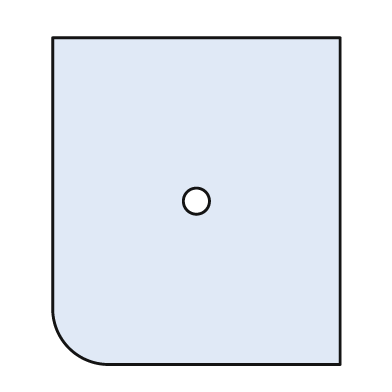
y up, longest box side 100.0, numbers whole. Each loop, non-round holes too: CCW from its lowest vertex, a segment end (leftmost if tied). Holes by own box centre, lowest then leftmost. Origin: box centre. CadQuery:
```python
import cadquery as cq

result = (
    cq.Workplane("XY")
    .moveTo(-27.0, -50.0)
    .lineTo(44.0, -50.0)
    .lineTo(44.0, 50.0)
    .lineTo(-44.0, 50.0)
    .lineTo(-44.0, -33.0)
    .threePointArc((-39.0, -45.0), (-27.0, -50.0))
    .close()
    .moveTo(0.0, 0.0)
    .circle(4.0)
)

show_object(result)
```